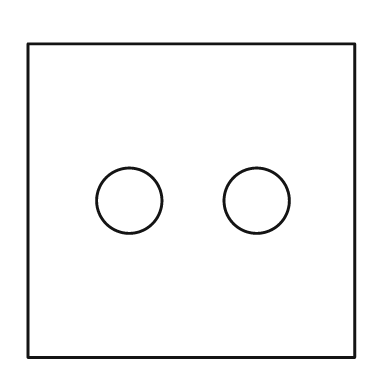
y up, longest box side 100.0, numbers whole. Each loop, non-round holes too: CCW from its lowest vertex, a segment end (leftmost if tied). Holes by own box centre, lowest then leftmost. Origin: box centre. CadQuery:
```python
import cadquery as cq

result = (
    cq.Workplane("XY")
    .moveTo(-50.0, -48.0)
    .lineTo(50.0, -48.0)
    .lineTo(50.0, 48.0)
    .lineTo(-50.0, 48.0)
    .close()
    .moveTo(-19.0, 0.0)
    .circle(10.0)
    .moveTo(20.0, 0.0)
    .circle(10.0)
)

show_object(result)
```